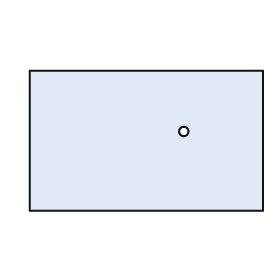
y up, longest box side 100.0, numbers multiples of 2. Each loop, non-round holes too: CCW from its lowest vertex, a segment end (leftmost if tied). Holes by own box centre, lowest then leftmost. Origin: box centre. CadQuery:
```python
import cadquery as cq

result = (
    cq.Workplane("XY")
    .moveTo(-50.0, -30.0)
    .lineTo(50.0, -30.0)
    .lineTo(50.0, 30.0)
    .lineTo(-50.0, 30.0)
    .close()
    .moveTo(16.0, 4.0)
    .circle(2.0)
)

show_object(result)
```